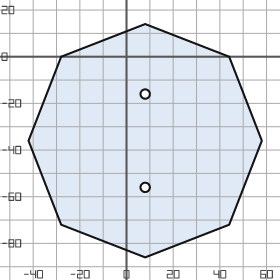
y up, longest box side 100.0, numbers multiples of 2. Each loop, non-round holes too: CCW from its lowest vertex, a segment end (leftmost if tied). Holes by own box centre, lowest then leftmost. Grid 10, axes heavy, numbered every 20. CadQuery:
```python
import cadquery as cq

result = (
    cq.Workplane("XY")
    .moveTo(8.0, -86.0)
    .lineTo(44.0, -72.0)
    .lineTo(58.0, -36.0)
    .lineTo(44.0, 0.0)
    .lineTo(8.0, 14.0)
    .lineTo(-28.0, 0.0)
    .lineTo(-42.0, -36.0)
    .lineTo(-28.0, -72.0)
    .close()
    .moveTo(8.0, -56.0)
    .circle(2.0)
    .moveTo(8.0, -16.0)
    .circle(2.0)
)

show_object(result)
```